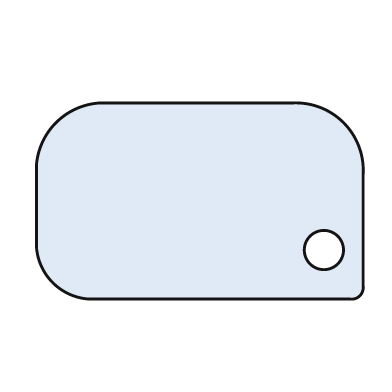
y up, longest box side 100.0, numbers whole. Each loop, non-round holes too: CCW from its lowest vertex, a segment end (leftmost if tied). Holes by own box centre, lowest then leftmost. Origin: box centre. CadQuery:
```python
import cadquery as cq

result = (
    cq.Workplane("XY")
    .moveTo(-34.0, -30.0)
    .lineTo(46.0, -30.0)
    .threePointArc((49.0, -29.0), (50.0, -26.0))
    .lineTo(50.0, 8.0)
    .threePointArc((44.0, 24.0), (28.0, 30.0))
    .lineTo(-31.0, 30.0)
    .threePointArc((-44.0, 24.0), (-50.0, 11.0))
    .lineTo(-50.0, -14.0)
    .threePointArc((-45.0, -25.0), (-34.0, -30.0))
    .close()
    .moveTo(38.0, -15.0)
    .circle(6.0)
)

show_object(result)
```